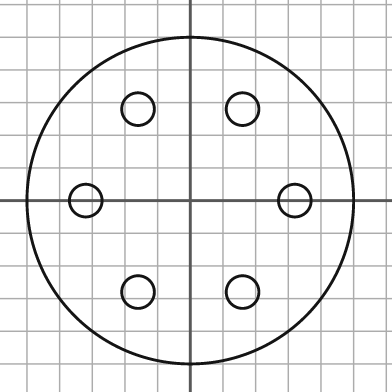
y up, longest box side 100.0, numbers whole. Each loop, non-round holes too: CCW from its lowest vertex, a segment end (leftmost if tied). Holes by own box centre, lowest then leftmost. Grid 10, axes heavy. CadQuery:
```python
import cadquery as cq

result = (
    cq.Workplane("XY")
    .moveTo(0.0, 0.0)
    .circle(50.0)
    .moveTo(-16.0, -28.0)
    .circle(5.0)
    .moveTo(16.0, -28.0)
    .circle(5.0)
    .moveTo(-32.0, 0.0)
    .circle(5.0)
    .moveTo(32.0, 0.0)
    .circle(5.0)
    .moveTo(-16.0, 28.0)
    .circle(5.0)
    .moveTo(16.0, 28.0)
    .circle(5.0)
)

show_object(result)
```